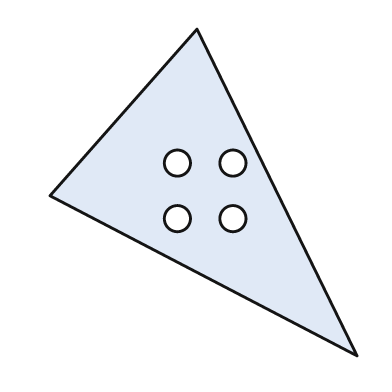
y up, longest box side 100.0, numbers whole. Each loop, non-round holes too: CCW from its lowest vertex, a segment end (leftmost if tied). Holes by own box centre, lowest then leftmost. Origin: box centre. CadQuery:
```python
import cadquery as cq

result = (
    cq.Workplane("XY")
    .moveTo(47.0, -50.0)
    .lineTo(-2.0, 50.0)
    .lineTo(-47.0, -1.0)
    .close()
    .moveTo(-8.0, -8.0)
    .circle(4.0)
    .moveTo(9.0, -8.0)
    .circle(4.0)
    .moveTo(-8.0, 9.0)
    .circle(4.0)
    .moveTo(9.0, 9.0)
    .circle(4.0)
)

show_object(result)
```